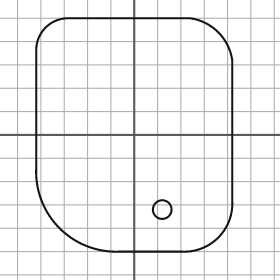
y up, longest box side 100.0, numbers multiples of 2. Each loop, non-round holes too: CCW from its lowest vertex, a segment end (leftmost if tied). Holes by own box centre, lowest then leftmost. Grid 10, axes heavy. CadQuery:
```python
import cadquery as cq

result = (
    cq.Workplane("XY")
    .moveTo(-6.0, -50.0)
    .lineTo(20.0, -50.0)
    .threePointArc((36.0, -44.0), (42.0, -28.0))
    .lineTo(42.0, 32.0)
    .threePointArc((36.0, 44.0), (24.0, 50.0))
    .lineTo(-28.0, 50.0)
    .threePointArc((-38.0, 46.0), (-42.0, 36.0))
    .lineTo(-42.0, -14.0)
    .threePointArc((-32.0, -40.0), (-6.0, -50.0))
    .close()
    .moveTo(12.0, -32.0)
    .circle(4.0)
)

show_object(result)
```